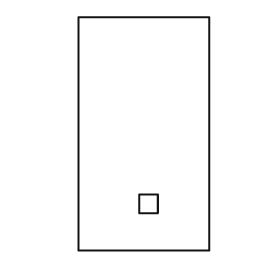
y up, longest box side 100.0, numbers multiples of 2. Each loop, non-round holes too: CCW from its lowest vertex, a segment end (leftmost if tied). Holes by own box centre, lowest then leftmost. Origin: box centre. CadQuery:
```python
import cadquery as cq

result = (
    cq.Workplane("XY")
    .moveTo(-28.0, -50.0)
    .lineTo(28.0, -50.0)
    .lineTo(28.0, 50.0)
    .lineTo(-28.0, 50.0)
    .close()
    .moveTo(-2.0, -34.0)
    .lineTo(6.0, -34.0)
    .lineTo(6.0, -26.0)
    .lineTo(-2.0, -26.0)
    .close()
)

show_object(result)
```